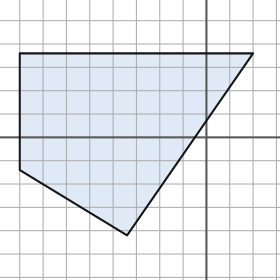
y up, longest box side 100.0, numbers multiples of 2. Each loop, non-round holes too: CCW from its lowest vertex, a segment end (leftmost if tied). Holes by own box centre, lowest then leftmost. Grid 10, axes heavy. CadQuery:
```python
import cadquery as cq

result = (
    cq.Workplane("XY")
    .moveTo(-34.0, -42.0)
    .lineTo(20.0, 36.0)
    .lineTo(-80.0, 36.0)
    .lineTo(-80.0, -14.0)
    .close()
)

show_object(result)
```